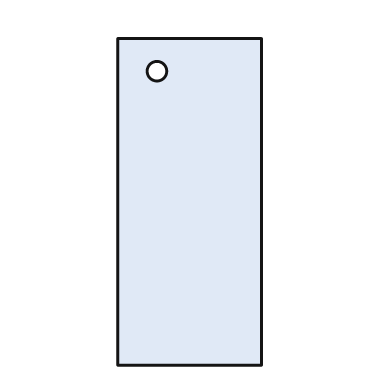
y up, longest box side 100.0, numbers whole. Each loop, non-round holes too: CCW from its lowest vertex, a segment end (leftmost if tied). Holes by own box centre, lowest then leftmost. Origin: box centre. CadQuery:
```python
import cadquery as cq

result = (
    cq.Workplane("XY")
    .moveTo(-22.0, -50.0)
    .lineTo(22.0, -50.0)
    .lineTo(22.0, 50.0)
    .lineTo(-22.0, 50.0)
    .close()
    .moveTo(-10.0, 40.0)
    .circle(3.0)
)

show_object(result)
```